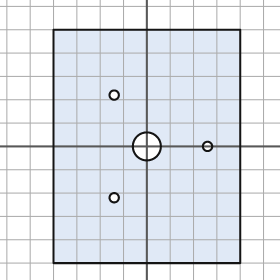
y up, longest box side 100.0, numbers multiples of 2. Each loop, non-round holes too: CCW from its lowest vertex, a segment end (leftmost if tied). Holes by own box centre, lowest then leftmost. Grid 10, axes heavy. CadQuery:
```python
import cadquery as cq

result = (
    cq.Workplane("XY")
    .moveTo(-40.0, -50.0)
    .lineTo(40.0, -50.0)
    .lineTo(40.0, 50.0)
    .lineTo(-40.0, 50.0)
    .close()
    .moveTo(-14.0, -22.0)
    .circle(2.0)
    .moveTo(0.0, 0.0)
    .circle(6.0)
    .moveTo(26.0, 0.0)
    .circle(2.0)
    .moveTo(-14.0, 22.0)
    .circle(2.0)
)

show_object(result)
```